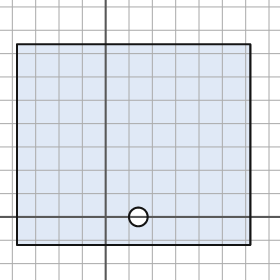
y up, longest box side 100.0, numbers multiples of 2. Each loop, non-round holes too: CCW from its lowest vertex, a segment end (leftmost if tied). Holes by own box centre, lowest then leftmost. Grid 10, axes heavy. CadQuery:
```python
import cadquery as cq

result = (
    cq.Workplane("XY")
    .moveTo(-38.0, -12.0)
    .lineTo(62.0, -12.0)
    .lineTo(62.0, 74.0)
    .lineTo(-38.0, 74.0)
    .close()
    .moveTo(14.0, 0.0)
    .circle(4.0)
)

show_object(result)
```